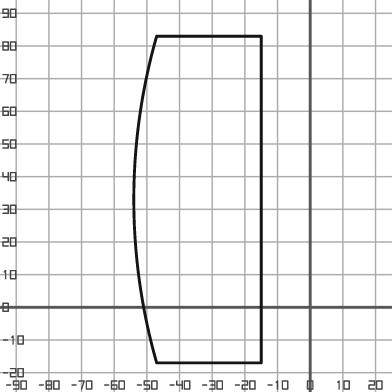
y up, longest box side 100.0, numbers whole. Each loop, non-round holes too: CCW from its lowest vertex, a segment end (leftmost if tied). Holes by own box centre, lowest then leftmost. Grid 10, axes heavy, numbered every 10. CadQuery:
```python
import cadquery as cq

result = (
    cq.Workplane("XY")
    .moveTo(-47.0, -17.0)
    .lineTo(-15.0, -17.0)
    .lineTo(-15.0, 83.0)
    .lineTo(-47.0, 83.0)
    .threePointArc((-54.0, 33.0), (-47.0, -17.0))
    .close()
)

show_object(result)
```